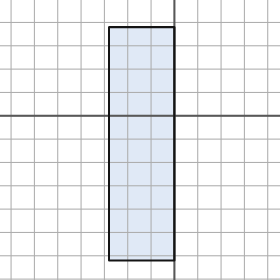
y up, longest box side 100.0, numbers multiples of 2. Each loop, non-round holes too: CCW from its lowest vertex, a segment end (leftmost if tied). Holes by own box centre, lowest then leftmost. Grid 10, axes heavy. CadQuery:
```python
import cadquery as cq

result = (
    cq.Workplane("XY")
    .moveTo(-28.0, -62.0)
    .lineTo(0.0, -62.0)
    .lineTo(0.0, 38.0)
    .lineTo(-28.0, 38.0)
    .close()
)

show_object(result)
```